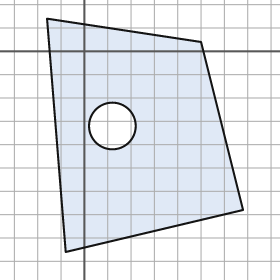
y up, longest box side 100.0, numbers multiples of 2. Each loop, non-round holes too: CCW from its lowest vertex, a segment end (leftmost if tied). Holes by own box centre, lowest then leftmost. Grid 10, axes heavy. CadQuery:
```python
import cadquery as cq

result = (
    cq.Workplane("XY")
    .moveTo(-8.0, -86.0)
    .lineTo(68.0, -68.0)
    .lineTo(50.0, 4.0)
    .lineTo(-16.0, 14.0)
    .close()
    .moveTo(12.0, -32.0)
    .circle(10.0)
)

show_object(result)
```